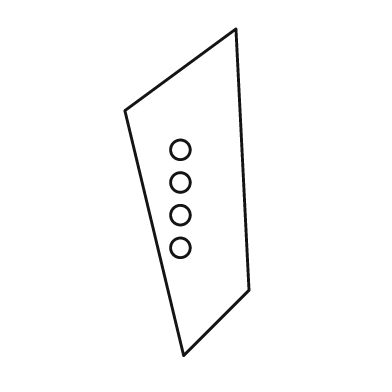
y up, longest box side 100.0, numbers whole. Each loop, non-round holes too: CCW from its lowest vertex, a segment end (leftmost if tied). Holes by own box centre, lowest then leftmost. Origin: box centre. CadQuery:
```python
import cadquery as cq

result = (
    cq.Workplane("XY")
    .moveTo(-1.0, -50.0)
    .lineTo(19.0, -30.0)
    .lineTo(15.0, 50.0)
    .lineTo(-19.0, 25.0)
    .close()
    .moveTo(-2.0, -17.0)
    .circle(3.0)
    .moveTo(-2.0, -7.0)
    .circle(3.0)
    .moveTo(-2.0, 3.0)
    .circle(3.0)
    .moveTo(-2.0, 13.0)
    .circle(3.0)
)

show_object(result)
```